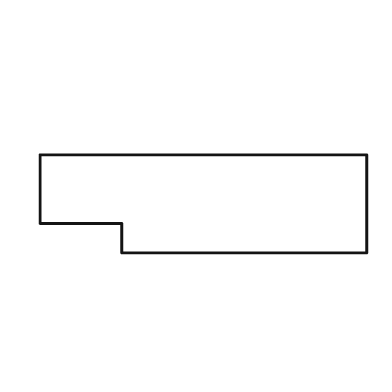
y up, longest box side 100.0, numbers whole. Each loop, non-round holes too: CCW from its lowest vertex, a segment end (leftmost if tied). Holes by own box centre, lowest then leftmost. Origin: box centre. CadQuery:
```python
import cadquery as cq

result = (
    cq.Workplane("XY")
    .moveTo(-25.0, -15.0)
    .lineTo(50.0, -15.0)
    .lineTo(50.0, 15.0)
    .lineTo(-50.0, 15.0)
    .lineTo(-50.0, -6.0)
    .lineTo(-25.0, -6.0)
    .close()
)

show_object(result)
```